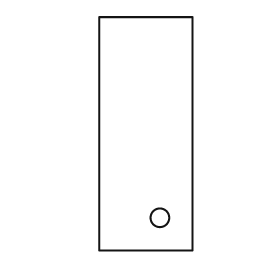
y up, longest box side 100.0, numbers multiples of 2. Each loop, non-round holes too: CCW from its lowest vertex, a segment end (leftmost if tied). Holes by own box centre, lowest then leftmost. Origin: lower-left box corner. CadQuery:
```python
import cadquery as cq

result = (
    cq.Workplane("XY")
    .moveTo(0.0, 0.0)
    .lineTo(40.0, 0.0)
    .lineTo(40.0, 100.0)
    .lineTo(0.0, 100.0)
    .close()
    .moveTo(26.0, 14.0)
    .circle(4.0)
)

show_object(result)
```